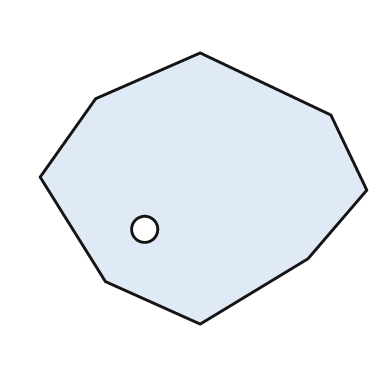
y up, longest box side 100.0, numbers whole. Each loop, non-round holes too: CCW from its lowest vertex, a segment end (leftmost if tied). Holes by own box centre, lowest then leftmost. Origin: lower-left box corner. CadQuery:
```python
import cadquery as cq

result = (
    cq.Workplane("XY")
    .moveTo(49.0, 0.0)
    .lineTo(82.0, 20.0)
    .lineTo(100.0, 41.0)
    .lineTo(89.0, 64.0)
    .lineTo(49.0, 83.0)
    .lineTo(17.0, 69.0)
    .lineTo(0.0, 45.0)
    .lineTo(20.0, 13.0)
    .close()
    .moveTo(32.0, 29.0)
    .circle(4.0)
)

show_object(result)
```